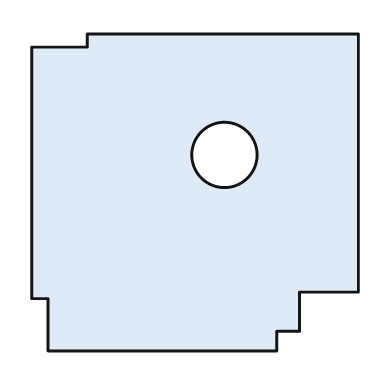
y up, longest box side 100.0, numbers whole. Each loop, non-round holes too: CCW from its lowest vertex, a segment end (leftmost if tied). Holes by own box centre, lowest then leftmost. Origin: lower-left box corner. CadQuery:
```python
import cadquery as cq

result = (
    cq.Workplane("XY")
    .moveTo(5.0, 0.0)
    .lineTo(75.0, 0.0)
    .lineTo(75.0, 6.0)
    .lineTo(82.0, 6.0)
    .lineTo(82.0, 18.0)
    .lineTo(100.0, 18.0)
    .lineTo(100.0, 97.0)
    .lineTo(17.0, 97.0)
    .lineTo(17.0, 93.0)
    .lineTo(0.0, 93.0)
    .lineTo(0.0, 16.0)
    .lineTo(5.0, 16.0)
    .close()
    .moveTo(59.0, 60.0)
    .circle(10.0)
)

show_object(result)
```